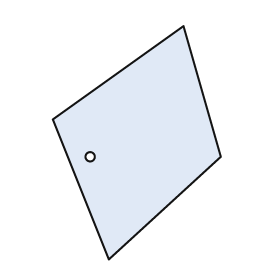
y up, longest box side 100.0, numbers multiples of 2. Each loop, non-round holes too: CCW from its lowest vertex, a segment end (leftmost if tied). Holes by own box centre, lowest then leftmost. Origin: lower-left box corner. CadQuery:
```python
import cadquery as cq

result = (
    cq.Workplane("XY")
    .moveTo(24.0, 0.0)
    .lineTo(72.0, 44.0)
    .lineTo(56.0, 100.0)
    .lineTo(0.0, 60.0)
    .close()
    .moveTo(16.0, 44.0)
    .circle(2.0)
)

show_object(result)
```